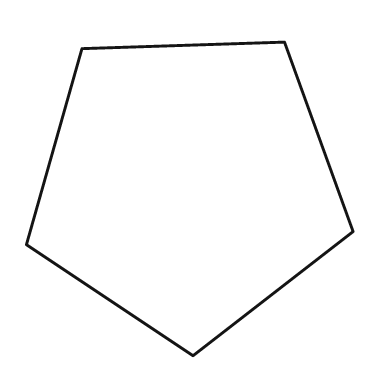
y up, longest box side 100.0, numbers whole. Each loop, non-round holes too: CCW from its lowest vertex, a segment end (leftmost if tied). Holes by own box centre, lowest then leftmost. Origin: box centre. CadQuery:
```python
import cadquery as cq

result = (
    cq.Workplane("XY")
    .moveTo(1.0, -48.0)
    .lineTo(50.0, -10.0)
    .lineTo(29.0, 48.0)
    .lineTo(-33.0, 46.0)
    .lineTo(-50.0, -14.0)
    .close()
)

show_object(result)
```